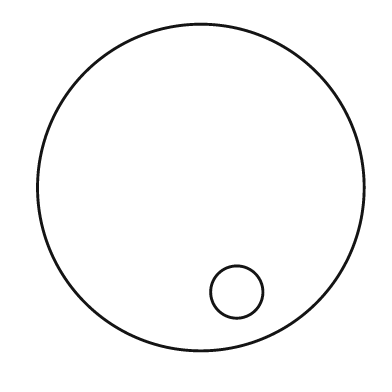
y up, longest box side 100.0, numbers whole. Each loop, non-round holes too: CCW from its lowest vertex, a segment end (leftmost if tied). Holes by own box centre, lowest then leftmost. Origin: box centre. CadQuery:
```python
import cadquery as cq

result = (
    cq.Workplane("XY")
    .moveTo(0.0, 0.0)
    .circle(50.0)
    .moveTo(11.0, -32.0)
    .circle(8.0)
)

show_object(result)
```